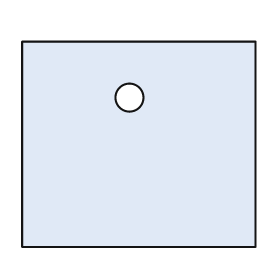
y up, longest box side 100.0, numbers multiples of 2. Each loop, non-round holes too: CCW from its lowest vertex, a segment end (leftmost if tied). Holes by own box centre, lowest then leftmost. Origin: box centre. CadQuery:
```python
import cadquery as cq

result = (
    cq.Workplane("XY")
    .moveTo(-50.0, -44.0)
    .lineTo(50.0, -44.0)
    .lineTo(50.0, 44.0)
    .lineTo(-50.0, 44.0)
    .close()
    .moveTo(-4.0, 20.0)
    .circle(6.0)
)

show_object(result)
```